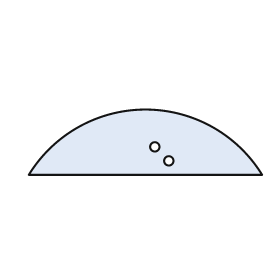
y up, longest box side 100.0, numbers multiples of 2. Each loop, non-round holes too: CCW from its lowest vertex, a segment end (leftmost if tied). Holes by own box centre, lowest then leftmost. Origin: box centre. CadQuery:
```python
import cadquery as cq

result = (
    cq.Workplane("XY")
    .moveTo(-50.0, -14.0)
    .lineTo(50.0, -14.0)
    .threePointArc((0.0, 14.0), (-50.0, -14.0))
    .close()
    .moveTo(10.0, -8.0)
    .circle(2.0)
    .moveTo(4.0, -2.0)
    .circle(2.0)
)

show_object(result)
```